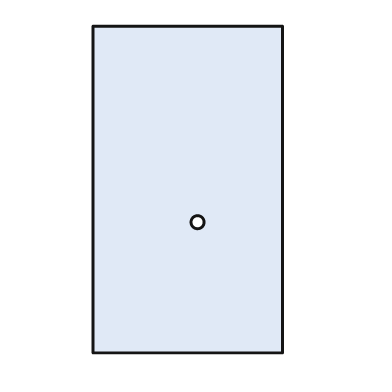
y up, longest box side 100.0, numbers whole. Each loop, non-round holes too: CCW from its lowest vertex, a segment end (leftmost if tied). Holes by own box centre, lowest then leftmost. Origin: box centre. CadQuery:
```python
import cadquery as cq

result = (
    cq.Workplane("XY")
    .moveTo(-29.0, -50.0)
    .lineTo(29.0, -50.0)
    .lineTo(29.0, 50.0)
    .lineTo(-29.0, 50.0)
    .close()
    .moveTo(3.0, -10.0)
    .circle(2.0)
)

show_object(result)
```